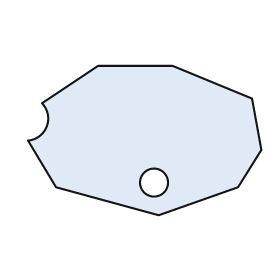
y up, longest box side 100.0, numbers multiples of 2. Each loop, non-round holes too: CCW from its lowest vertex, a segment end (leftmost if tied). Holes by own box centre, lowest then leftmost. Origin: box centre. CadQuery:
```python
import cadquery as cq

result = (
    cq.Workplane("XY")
    .moveTo(6.0, -32.0)
    .lineTo(40.0, -20.0)
    .lineTo(50.0, -4.0)
    .lineTo(46.0, 18.0)
    .lineTo(12.0, 32.0)
    .lineTo(-20.0, 32.0)
    .lineTo(-44.0, 16.0)
    .threePointArc((-42.0, 6.0), (-50.0, 0.0))
    .lineTo(-38.0, -20.0)
    .close()
    .moveTo(4.0, -18.0)
    .circle(6.0)
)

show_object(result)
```